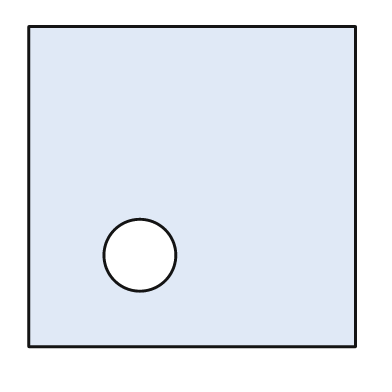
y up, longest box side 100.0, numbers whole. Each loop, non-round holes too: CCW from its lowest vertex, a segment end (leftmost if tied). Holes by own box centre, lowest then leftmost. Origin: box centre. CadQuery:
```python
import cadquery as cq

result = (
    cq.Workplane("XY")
    .moveTo(-50.0, -49.0)
    .lineTo(50.0, -49.0)
    .lineTo(50.0, 49.0)
    .lineTo(-50.0, 49.0)
    .close()
    .moveTo(-16.0, -21.0)
    .circle(11.0)
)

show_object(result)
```